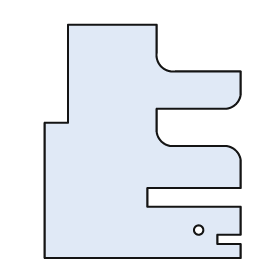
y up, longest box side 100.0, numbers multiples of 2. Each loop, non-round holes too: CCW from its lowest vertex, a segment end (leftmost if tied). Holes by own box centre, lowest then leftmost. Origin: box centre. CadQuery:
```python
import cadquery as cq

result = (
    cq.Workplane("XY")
    .moveTo(-42.0, -50.0)
    .lineTo(42.0, -50.0)
    .lineTo(42.0, -44.0)
    .lineTo(32.0, -44.0)
    .lineTo(32.0, -40.0)
    .lineTo(42.0, -40.0)
    .lineTo(42.0, -28.0)
    .lineTo(2.0, -28.0)
    .lineTo(2.0, -20.0)
    .lineTo(42.0, -20.0)
    .lineTo(42.0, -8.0)
    .threePointArc((40.0, -4.0), (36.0, -2.0))
    .lineTo(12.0, -2.0)
    .threePointArc((8.0, 0.0), (6.0, 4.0))
    .lineTo(6.0, 14.0)
    .lineTo(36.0, 14.0)
    .threePointArc((40.0, 16.0), (42.0, 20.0))
    .lineTo(42.0, 30.0)
    .lineTo(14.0, 30.0)
    .threePointArc((8.0, 32.0), (6.0, 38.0))
    .lineTo(6.0, 50.0)
    .lineTo(-32.0, 50.0)
    .lineTo(-32.0, 8.0)
    .lineTo(-42.0, 8.0)
    .close()
    .moveTo(24.0, -38.0)
    .circle(2.0)
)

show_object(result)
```